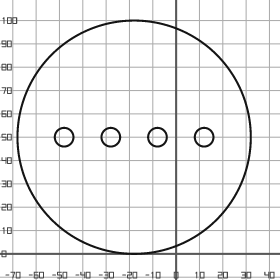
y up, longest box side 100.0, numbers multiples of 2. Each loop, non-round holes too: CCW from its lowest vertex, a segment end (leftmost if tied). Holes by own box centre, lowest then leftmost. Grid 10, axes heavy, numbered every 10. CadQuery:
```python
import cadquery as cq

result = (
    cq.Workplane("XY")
    .moveTo(-18.0, 50.0)
    .circle(50.0)
    .moveTo(-48.0, 50.0)
    .circle(4.0)
    .moveTo(-28.0, 50.0)
    .circle(4.0)
    .moveTo(-8.0, 50.0)
    .circle(4.0)
    .moveTo(12.0, 50.0)
    .circle(4.0)
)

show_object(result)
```